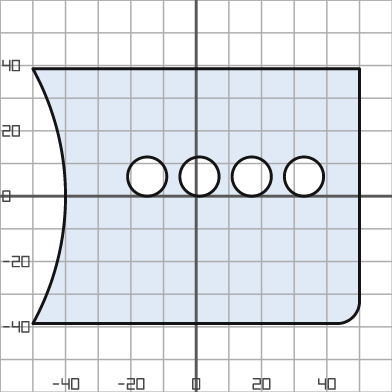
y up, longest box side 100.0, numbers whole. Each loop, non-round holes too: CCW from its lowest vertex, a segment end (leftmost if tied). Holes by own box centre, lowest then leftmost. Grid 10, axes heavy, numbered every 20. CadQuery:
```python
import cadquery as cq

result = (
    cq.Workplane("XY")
    .moveTo(-50.0, -39.0)
    .lineTo(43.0, -39.0)
    .threePointArc((48.0, -37.0), (50.0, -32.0))
    .lineTo(50.0, 39.0)
    .lineTo(-50.0, 39.0)
    .threePointArc((-40.0, 0.0), (-50.0, -39.0))
    .close()
    .moveTo(-15.0, 6.0)
    .circle(6.0)
    .moveTo(1.0, 6.0)
    .circle(6.0)
    .moveTo(17.0, 6.0)
    .circle(6.0)
    .moveTo(33.0, 6.0)
    .circle(6.0)
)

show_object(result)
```